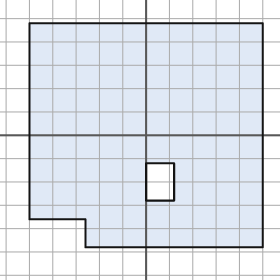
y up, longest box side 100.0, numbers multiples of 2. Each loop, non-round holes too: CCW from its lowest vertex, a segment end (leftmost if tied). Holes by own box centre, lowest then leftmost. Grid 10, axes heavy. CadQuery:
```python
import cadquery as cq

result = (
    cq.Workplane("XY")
    .moveTo(-26.0, -48.0)
    .lineTo(50.0, -48.0)
    .lineTo(50.0, 48.0)
    .lineTo(-50.0, 48.0)
    .lineTo(-50.0, -36.0)
    .lineTo(-26.0, -36.0)
    .close()
    .moveTo(0.0, -28.0)
    .lineTo(12.0, -28.0)
    .lineTo(12.0, -12.0)
    .lineTo(0.0, -12.0)
    .close()
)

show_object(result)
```